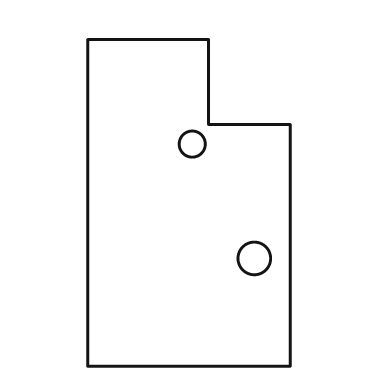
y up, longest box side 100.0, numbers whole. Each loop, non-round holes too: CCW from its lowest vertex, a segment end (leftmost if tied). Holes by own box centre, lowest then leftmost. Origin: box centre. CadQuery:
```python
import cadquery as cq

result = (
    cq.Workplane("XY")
    .moveTo(-31.0, -50.0)
    .lineTo(31.0, -50.0)
    .lineTo(31.0, 24.0)
    .lineTo(6.0, 24.0)
    .lineTo(6.0, 50.0)
    .lineTo(-31.0, 50.0)
    .close()
    .moveTo(20.0, -17.0)
    .circle(5.0)
    .moveTo(1.0, 18.0)
    .circle(4.0)
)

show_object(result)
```